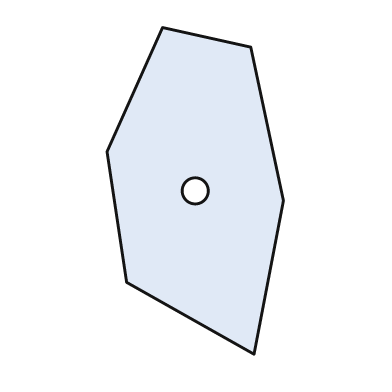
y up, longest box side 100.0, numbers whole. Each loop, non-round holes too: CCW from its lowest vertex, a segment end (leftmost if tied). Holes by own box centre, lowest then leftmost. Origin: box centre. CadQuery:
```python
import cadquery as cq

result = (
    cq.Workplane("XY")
    .moveTo(18.0, -50.0)
    .lineTo(27.0, -3.0)
    .lineTo(17.0, 44.0)
    .lineTo(-10.0, 50.0)
    .lineTo(-27.0, 12.0)
    .lineTo(-21.0, -28.0)
    .close()
    .moveTo(0.0, 0.0)
    .circle(4.0)
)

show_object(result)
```